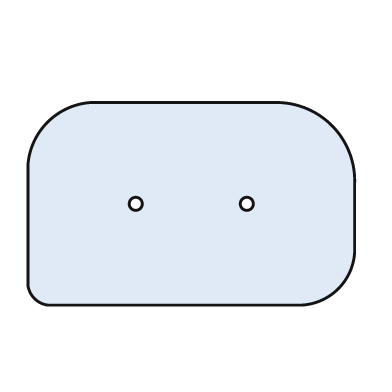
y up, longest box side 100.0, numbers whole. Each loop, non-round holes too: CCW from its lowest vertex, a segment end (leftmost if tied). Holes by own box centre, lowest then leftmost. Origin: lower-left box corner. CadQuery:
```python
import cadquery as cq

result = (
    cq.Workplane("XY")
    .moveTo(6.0, 0.0)
    .lineTo(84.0, 0.0)
    .threePointArc((95.0, 5.0), (100.0, 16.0))
    .lineTo(100.0, 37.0)
    .threePointArc((93.0, 55.0), (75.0, 62.0))
    .lineTo(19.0, 62.0)
    .threePointArc((6.0, 56.0), (0.0, 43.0))
    .lineTo(0.0, 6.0)
    .threePointArc((2.0, 2.0), (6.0, 0.0))
    .close()
    .moveTo(33.0, 31.0)
    .circle(2.0)
    .moveTo(67.0, 31.0)
    .circle(2.0)
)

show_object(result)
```